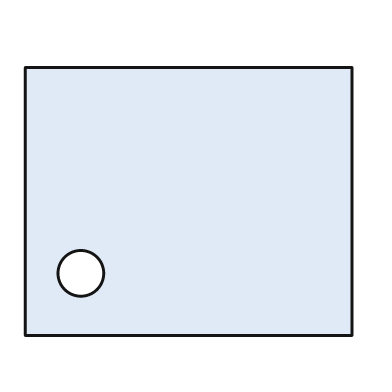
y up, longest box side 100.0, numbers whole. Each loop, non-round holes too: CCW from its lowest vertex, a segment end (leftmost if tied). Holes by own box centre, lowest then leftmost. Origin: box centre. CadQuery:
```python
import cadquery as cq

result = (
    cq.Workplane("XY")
    .moveTo(-50.0, -41.0)
    .lineTo(50.0, -41.0)
    .lineTo(50.0, 41.0)
    .lineTo(-50.0, 41.0)
    .close()
    .moveTo(-33.0, -22.0)
    .circle(7.0)
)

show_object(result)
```